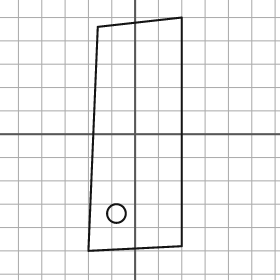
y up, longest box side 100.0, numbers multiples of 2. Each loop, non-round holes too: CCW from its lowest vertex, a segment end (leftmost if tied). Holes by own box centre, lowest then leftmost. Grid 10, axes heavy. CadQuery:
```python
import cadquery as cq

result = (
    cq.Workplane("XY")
    .moveTo(-20.0, -50.0)
    .lineTo(20.0, -48.0)
    .lineTo(20.0, 50.0)
    .lineTo(-16.0, 46.0)
    .close()
    .moveTo(-8.0, -34.0)
    .circle(4.0)
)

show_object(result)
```